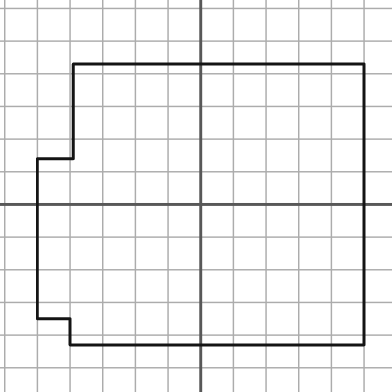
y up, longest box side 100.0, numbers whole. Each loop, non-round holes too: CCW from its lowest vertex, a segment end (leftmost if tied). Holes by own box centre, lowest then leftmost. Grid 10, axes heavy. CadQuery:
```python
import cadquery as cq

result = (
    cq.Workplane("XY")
    .moveTo(-40.0, -43.0)
    .lineTo(50.0, -43.0)
    .lineTo(50.0, 43.0)
    .lineTo(-39.0, 43.0)
    .lineTo(-39.0, 14.0)
    .lineTo(-50.0, 14.0)
    .lineTo(-50.0, -35.0)
    .lineTo(-40.0, -35.0)
    .close()
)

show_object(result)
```